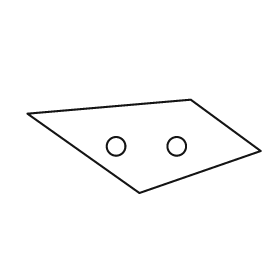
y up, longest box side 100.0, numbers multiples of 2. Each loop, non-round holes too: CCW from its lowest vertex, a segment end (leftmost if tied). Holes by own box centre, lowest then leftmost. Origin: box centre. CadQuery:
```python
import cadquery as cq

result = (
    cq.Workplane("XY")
    .moveTo(-2.0, -20.0)
    .lineTo(50.0, -2.0)
    .lineTo(20.0, 20.0)
    .lineTo(-50.0, 14.0)
    .close()
    .moveTo(-12.0, 0.0)
    .circle(4.0)
    .moveTo(14.0, 0.0)
    .circle(4.0)
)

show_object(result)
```